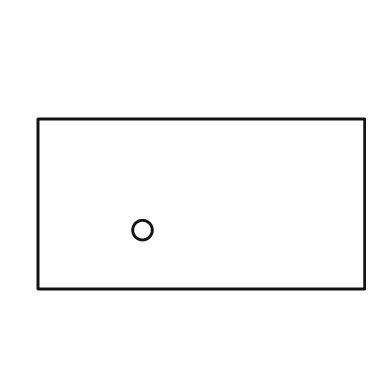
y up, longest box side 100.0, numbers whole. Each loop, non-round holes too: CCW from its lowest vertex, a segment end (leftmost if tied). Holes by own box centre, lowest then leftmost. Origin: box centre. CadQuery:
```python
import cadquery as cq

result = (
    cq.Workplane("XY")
    .moveTo(-50.0, -26.0)
    .lineTo(50.0, -26.0)
    .lineTo(50.0, 26.0)
    .lineTo(-50.0, 26.0)
    .close()
    .moveTo(-18.0, -8.0)
    .circle(3.0)
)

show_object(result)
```